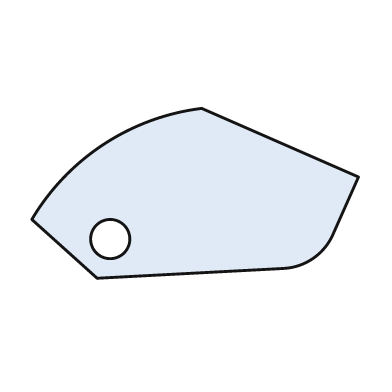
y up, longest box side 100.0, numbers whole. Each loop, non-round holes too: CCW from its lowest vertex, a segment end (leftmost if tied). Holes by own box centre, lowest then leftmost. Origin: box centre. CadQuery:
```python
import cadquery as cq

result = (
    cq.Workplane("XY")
    .moveTo(-30.0, -26.0)
    .lineTo(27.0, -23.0)
    .threePointArc((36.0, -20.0), (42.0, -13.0))
    .lineTo(50.0, 5.0)
    .lineTo(2.0, 26.0)
    .threePointArc((-28.0, 15.0), (-50.0, -8.0))
    .close()
    .moveTo(-26.0, -14.0)
    .circle(6.0)
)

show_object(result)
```